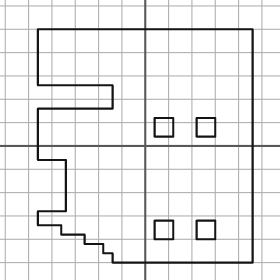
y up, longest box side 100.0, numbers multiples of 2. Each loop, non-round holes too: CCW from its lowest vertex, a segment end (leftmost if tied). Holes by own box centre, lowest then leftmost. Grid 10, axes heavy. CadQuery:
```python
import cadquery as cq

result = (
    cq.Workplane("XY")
    .moveTo(-14.0, -50.0)
    .lineTo(46.0, -50.0)
    .lineTo(46.0, 50.0)
    .lineTo(-46.0, 50.0)
    .lineTo(-46.0, 26.0)
    .lineTo(-14.0, 26.0)
    .lineTo(-14.0, 16.0)
    .lineTo(-46.0, 16.0)
    .lineTo(-46.0, -6.0)
    .lineTo(-34.0, -6.0)
    .lineTo(-34.0, -28.0)
    .lineTo(-46.0, -28.0)
    .lineTo(-46.0, -34.0)
    .lineTo(-36.0, -34.0)
    .lineTo(-36.0, -38.0)
    .lineTo(-26.0, -38.0)
    .lineTo(-26.0, -42.0)
    .lineTo(-18.0, -42.0)
    .lineTo(-18.0, -46.0)
    .lineTo(-14.0, -46.0)
    .close()
    .moveTo(4.0, -40.0)
    .lineTo(12.0, -40.0)
    .lineTo(12.0, -32.0)
    .lineTo(4.0, -32.0)
    .close()
    .moveTo(22.0, -40.0)
    .lineTo(30.0, -40.0)
    .lineTo(30.0, -32.0)
    .lineTo(22.0, -32.0)
    .close()
    .moveTo(4.0, 4.0)
    .lineTo(12.0, 4.0)
    .lineTo(12.0, 12.0)
    .lineTo(4.0, 12.0)
    .close()
    .moveTo(22.0, 4.0)
    .lineTo(30.0, 4.0)
    .lineTo(30.0, 12.0)
    .lineTo(22.0, 12.0)
    .close()
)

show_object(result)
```